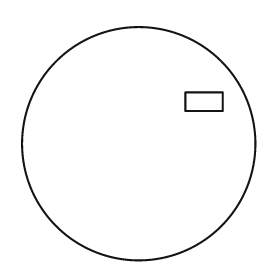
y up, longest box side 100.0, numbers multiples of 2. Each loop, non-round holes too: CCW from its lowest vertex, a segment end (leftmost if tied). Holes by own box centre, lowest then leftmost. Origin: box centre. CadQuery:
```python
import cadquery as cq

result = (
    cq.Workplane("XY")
    .moveTo(0.0, 0.0)
    .circle(50.0)
    .moveTo(20.0, 14.0)
    .lineTo(36.0, 14.0)
    .lineTo(36.0, 22.0)
    .lineTo(20.0, 22.0)
    .close()
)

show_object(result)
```